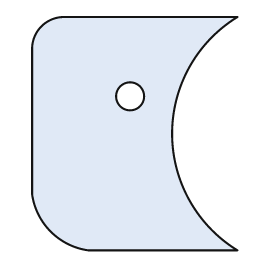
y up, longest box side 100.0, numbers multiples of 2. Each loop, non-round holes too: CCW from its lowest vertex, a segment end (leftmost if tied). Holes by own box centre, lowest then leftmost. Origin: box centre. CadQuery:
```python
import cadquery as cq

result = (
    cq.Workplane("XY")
    .moveTo(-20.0, -50.0)
    .lineTo(44.0, -50.0)
    .threePointArc((16.0, 0.0), (44.0, 50.0))
    .lineTo(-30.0, 50.0)
    .threePointArc((-40.0, 46.0), (-44.0, 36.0))
    .lineTo(-44.0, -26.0)
    .threePointArc((-36.0, -42.0), (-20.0, -50.0))
    .close()
    .moveTo(-2.0, 16.0)
    .circle(6.0)
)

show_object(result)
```